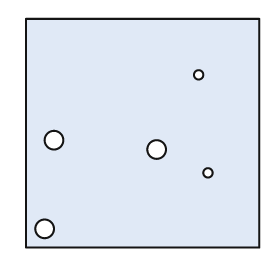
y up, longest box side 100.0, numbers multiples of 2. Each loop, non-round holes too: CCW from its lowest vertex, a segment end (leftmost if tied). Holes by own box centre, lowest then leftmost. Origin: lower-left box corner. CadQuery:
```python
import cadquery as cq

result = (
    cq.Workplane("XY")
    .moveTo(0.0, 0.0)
    .lineTo(100.0, 0.0)
    .lineTo(100.0, 98.0)
    .lineTo(0.0, 98.0)
    .close()
    .moveTo(8.0, 8.0)
    .circle(4.0)
    .moveTo(78.0, 32.0)
    .circle(2.0)
    .moveTo(56.0, 42.0)
    .circle(4.0)
    .moveTo(12.0, 46.0)
    .circle(4.0)
    .moveTo(74.0, 74.0)
    .circle(2.0)
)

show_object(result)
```